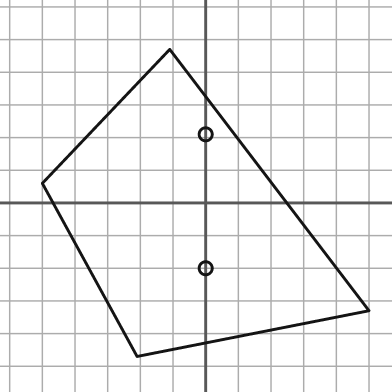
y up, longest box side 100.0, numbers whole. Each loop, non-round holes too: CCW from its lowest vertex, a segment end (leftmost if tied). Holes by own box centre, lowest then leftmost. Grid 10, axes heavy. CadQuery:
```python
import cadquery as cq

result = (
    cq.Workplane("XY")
    .moveTo(-21.0, -47.0)
    .lineTo(50.0, -33.0)
    .lineTo(-11.0, 47.0)
    .lineTo(-50.0, 6.0)
    .close()
    .moveTo(0.0, -20.0)
    .circle(2.0)
    .moveTo(0.0, 21.0)
    .circle(2.0)
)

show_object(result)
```